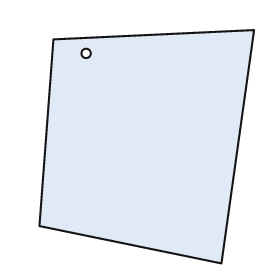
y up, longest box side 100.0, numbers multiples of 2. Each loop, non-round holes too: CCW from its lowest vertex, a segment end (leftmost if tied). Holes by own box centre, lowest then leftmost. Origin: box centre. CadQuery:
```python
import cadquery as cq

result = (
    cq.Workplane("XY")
    .moveTo(32.0, -50.0)
    .lineTo(46.0, 50.0)
    .lineTo(-40.0, 46.0)
    .lineTo(-46.0, -34.0)
    .close()
    .moveTo(-26.0, 40.0)
    .circle(2.0)
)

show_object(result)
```